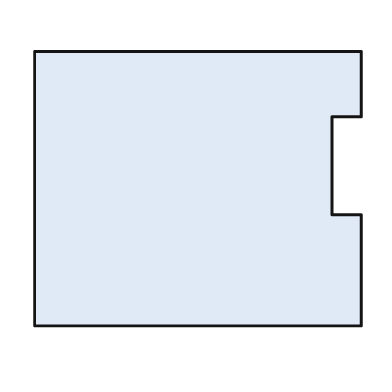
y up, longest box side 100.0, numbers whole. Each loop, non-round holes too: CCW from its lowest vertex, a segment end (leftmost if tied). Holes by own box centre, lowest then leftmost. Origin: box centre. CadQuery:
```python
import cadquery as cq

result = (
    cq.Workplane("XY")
    .moveTo(-50.0, -42.0)
    .lineTo(50.0, -42.0)
    .lineTo(50.0, -8.0)
    .lineTo(41.0, -8.0)
    .lineTo(41.0, 22.0)
    .lineTo(50.0, 22.0)
    .lineTo(50.0, 42.0)
    .lineTo(-50.0, 42.0)
    .close()
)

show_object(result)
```